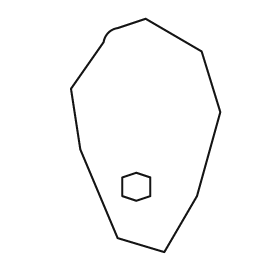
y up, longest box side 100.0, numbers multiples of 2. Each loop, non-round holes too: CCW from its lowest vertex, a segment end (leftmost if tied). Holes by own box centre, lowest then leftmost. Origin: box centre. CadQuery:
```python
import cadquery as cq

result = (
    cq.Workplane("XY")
    .moveTo(8.0, -50.0)
    .lineTo(22.0, -26.0)
    .lineTo(32.0, 10.0)
    .lineTo(24.0, 36.0)
    .lineTo(0.0, 50.0)
    .lineTo(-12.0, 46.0)
    .threePointArc((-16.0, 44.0), (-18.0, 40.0))
    .lineTo(-32.0, 20.0)
    .lineTo(-28.0, -6.0)
    .lineTo(-12.0, -44.0)
    .close()
    .moveTo(-4.0, -28.0)
    .lineTo(2.0, -26.0)
    .lineTo(2.0, -18.0)
    .lineTo(-4.0, -16.0)
    .lineTo(-10.0, -18.0)
    .lineTo(-10.0, -26.0)
    .close()
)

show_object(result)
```